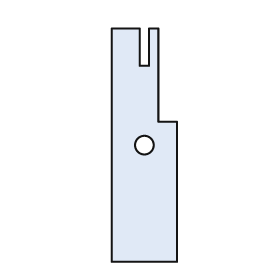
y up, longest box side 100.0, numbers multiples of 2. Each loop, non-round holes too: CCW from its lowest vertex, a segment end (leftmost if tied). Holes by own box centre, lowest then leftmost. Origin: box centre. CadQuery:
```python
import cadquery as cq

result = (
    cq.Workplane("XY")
    .moveTo(-14.0, -50.0)
    .lineTo(14.0, -50.0)
    .lineTo(14.0, 10.0)
    .lineTo(6.0, 10.0)
    .lineTo(6.0, 50.0)
    .lineTo(2.0, 50.0)
    .lineTo(2.0, 34.0)
    .lineTo(-2.0, 34.0)
    .lineTo(-2.0, 50.0)
    .lineTo(-14.0, 50.0)
    .close()
    .moveTo(0.0, 0.0)
    .circle(4.0)
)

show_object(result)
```